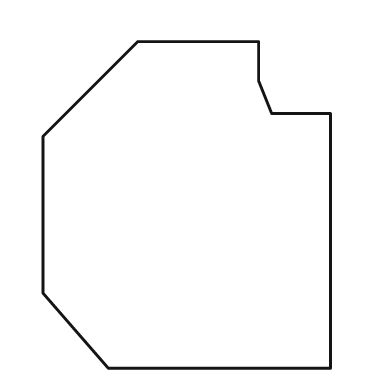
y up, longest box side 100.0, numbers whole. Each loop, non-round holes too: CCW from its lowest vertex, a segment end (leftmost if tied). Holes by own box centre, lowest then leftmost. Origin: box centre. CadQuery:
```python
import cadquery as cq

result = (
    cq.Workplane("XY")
    .moveTo(-24.0, -50.0)
    .lineTo(44.0, -50.0)
    .lineTo(44.0, 28.0)
    .lineTo(26.0, 28.0)
    .lineTo(22.0, 38.0)
    .lineTo(22.0, 50.0)
    .lineTo(-15.0, 50.0)
    .lineTo(-44.0, 21.0)
    .lineTo(-44.0, -27.0)
    .close()
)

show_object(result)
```